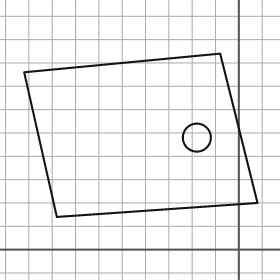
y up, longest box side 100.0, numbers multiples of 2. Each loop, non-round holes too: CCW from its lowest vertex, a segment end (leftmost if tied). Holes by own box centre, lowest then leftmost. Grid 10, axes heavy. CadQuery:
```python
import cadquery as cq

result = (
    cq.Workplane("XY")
    .moveTo(-78.0, 14.0)
    .lineTo(8.0, 20.0)
    .lineTo(-8.0, 84.0)
    .lineTo(-92.0, 76.0)
    .close()
    .moveTo(-18.0, 48.0)
    .circle(6.0)
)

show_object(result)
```